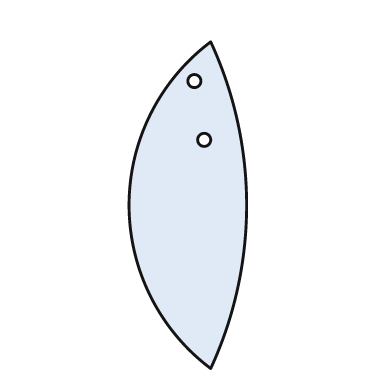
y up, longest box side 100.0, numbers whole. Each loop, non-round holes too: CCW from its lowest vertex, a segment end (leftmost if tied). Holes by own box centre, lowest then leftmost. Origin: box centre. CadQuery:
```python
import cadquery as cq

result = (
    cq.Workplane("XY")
    .moveTo(7.0, -50.0)
    .threePointArc((18.0, 0.0), (7.0, 50.0))
    .threePointArc((-18.0, 0.0), (7.0, -50.0))
    .close()
    .moveTo(5.0, 20.0)
    .circle(2.0)
    .moveTo(2.0, 38.0)
    .circle(2.0)
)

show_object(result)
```